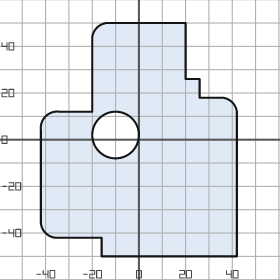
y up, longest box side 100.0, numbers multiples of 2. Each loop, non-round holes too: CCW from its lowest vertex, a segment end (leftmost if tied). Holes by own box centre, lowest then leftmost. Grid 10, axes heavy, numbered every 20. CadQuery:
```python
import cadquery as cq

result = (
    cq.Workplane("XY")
    .moveTo(-16.0, -50.0)
    .lineTo(42.0, -50.0)
    .lineTo(42.0, 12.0)
    .threePointArc((40.0, 16.0), (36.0, 18.0))
    .lineTo(26.0, 18.0)
    .lineTo(26.0, 26.0)
    .lineTo(20.0, 26.0)
    .lineTo(20.0, 50.0)
    .lineTo(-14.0, 50.0)
    .threePointArc((-18.0, 48.0), (-20.0, 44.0))
    .lineTo(-20.0, 12.0)
    .lineTo(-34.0, 12.0)
    .threePointArc((-40.0, 10.0), (-42.0, 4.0))
    .lineTo(-42.0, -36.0)
    .threePointArc((-40.0, -40.0), (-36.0, -42.0))
    .lineTo(-16.0, -42.0)
    .close()
    .moveTo(-10.0, 2.0)
    .circle(10.0)
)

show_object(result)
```